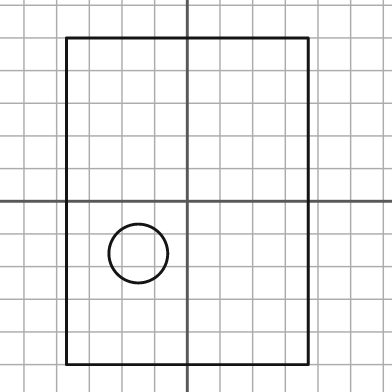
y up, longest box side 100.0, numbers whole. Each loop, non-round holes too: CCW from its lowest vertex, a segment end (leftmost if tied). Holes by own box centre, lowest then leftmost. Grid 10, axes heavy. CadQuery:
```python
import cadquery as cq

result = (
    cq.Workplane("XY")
    .moveTo(-37.0, -50.0)
    .lineTo(37.0, -50.0)
    .lineTo(37.0, 50.0)
    .lineTo(-37.0, 50.0)
    .close()
    .moveTo(-15.0, -16.0)
    .circle(9.0)
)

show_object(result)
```